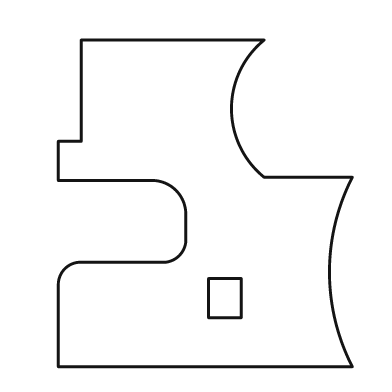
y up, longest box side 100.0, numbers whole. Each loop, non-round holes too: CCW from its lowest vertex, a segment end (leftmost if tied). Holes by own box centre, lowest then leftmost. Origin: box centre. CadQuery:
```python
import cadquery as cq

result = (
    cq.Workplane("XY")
    .moveTo(-45.0, -50.0)
    .lineTo(45.0, -50.0)
    .threePointArc((38.0, -21.0), (45.0, 8.0))
    .lineTo(18.0, 8.0)
    .threePointArc((8.0, 29.0), (18.0, 50.0))
    .lineTo(-38.0, 50.0)
    .lineTo(-38.0, 19.0)
    .lineTo(-45.0, 19.0)
    .lineTo(-45.0, 7.0)
    .lineTo(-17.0, 7.0)
    .threePointArc((-9.0, 4.0), (-6.0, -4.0))
    .lineTo(-6.0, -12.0)
    .threePointArc((-8.0, -16.0), (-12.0, -18.0))
    .lineTo(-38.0, -18.0)
    .threePointArc((-43.0, -20.0), (-45.0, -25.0))
    .close()
    .moveTo(1.0, -35.0)
    .lineTo(11.0, -35.0)
    .lineTo(11.0, -23.0)
    .lineTo(1.0, -23.0)
    .close()
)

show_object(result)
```